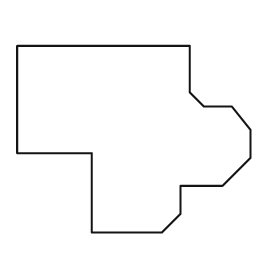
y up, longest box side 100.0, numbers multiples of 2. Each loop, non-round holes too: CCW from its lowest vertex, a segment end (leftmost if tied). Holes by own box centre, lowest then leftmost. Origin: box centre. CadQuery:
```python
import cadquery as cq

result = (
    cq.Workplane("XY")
    .moveTo(-18.0, -40.0)
    .lineTo(12.0, -40.0)
    .lineTo(20.0, -32.0)
    .lineTo(20.0, -20.0)
    .lineTo(38.0, -20.0)
    .lineTo(50.0, -8.0)
    .lineTo(50.0, 4.0)
    .lineTo(42.0, 14.0)
    .lineTo(30.0, 14.0)
    .lineTo(24.0, 20.0)
    .lineTo(24.0, 40.0)
    .lineTo(-50.0, 40.0)
    .lineTo(-50.0, -6.0)
    .lineTo(-18.0, -6.0)
    .close()
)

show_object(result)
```